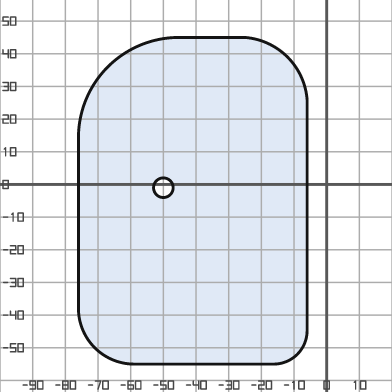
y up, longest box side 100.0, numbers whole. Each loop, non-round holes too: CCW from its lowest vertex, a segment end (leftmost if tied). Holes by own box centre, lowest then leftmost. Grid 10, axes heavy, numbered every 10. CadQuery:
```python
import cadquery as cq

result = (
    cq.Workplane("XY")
    .moveTo(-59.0, -55.0)
    .lineTo(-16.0, -55.0)
    .threePointArc((-9.0, -52.0), (-6.0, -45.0))
    .lineTo(-6.0, 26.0)
    .threePointArc((-12.0, 39.0), (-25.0, 45.0))
    .lineTo(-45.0, 45.0)
    .threePointArc((-67.0, 36.0), (-76.0, 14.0))
    .lineTo(-76.0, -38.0)
    .threePointArc((-71.0, -50.0), (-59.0, -55.0))
    .close()
    .moveTo(-50.0, -1.0)
    .circle(3.0)
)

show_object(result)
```